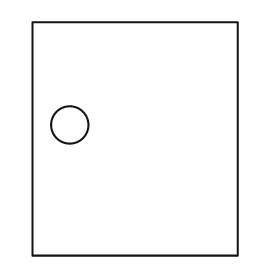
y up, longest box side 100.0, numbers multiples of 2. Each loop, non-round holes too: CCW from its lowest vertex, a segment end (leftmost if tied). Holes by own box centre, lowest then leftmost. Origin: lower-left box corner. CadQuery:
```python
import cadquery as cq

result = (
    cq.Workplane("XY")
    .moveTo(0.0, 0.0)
    .lineTo(88.0, 0.0)
    .lineTo(88.0, 100.0)
    .lineTo(0.0, 100.0)
    .close()
    .moveTo(16.0, 56.0)
    .circle(8.0)
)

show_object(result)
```